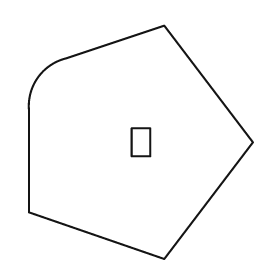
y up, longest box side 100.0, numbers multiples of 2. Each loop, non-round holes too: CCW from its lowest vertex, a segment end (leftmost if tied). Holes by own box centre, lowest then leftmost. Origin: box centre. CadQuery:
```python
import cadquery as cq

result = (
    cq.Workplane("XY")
    .moveTo(10.0, -50.0)
    .lineTo(48.0, 0.0)
    .lineTo(10.0, 50.0)
    .lineTo(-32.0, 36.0)
    .threePointArc((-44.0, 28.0), (-48.0, 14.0))
    .lineTo(-48.0, -30.0)
    .close()
    .moveTo(-4.0, -6.0)
    .lineTo(4.0, -6.0)
    .lineTo(4.0, 6.0)
    .lineTo(-4.0, 6.0)
    .close()
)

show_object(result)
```